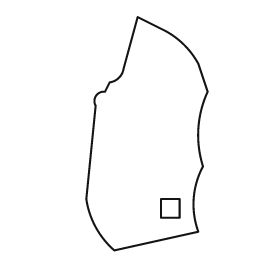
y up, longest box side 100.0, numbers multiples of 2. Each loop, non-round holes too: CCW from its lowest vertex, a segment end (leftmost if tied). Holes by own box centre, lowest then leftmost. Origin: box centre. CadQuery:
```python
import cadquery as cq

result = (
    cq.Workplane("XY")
    .moveTo(-14.0, -50.0)
    .lineTo(22.0, -42.0)
    .threePointArc((20.0, -28.0), (24.0, -14.0))
    .threePointArc((22.0, 2.0), (26.0, 18.0))
    .lineTo(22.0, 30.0)
    .threePointArc((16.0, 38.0), (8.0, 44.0))
    .lineTo(-4.0, 50.0)
    .lineTo(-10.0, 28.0)
    .threePointArc((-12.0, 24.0), (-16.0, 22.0))
    .lineTo(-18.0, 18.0)
    .threePointArc((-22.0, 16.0), (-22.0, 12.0))
    .lineTo(-26.0, -28.0)
    .threePointArc((-22.0, -40.0), (-14.0, -50.0))
    .close()
    .moveTo(6.0, -36.0)
    .lineTo(14.0, -36.0)
    .lineTo(14.0, -28.0)
    .lineTo(6.0, -28.0)
    .close()
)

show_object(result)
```